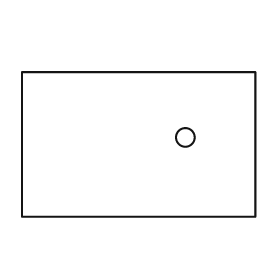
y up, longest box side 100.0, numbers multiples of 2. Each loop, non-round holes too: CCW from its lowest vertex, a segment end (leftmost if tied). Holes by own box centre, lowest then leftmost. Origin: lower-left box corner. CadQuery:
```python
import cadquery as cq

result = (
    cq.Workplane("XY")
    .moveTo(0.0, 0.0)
    .lineTo(100.0, 0.0)
    .lineTo(100.0, 62.0)
    .lineTo(0.0, 62.0)
    .close()
    .moveTo(70.0, 34.0)
    .circle(4.0)
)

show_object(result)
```